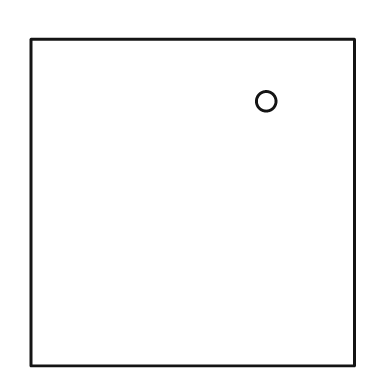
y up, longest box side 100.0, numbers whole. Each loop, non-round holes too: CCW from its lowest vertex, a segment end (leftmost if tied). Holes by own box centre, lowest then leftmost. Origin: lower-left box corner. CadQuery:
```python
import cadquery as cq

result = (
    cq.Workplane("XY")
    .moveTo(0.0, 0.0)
    .lineTo(99.0, 0.0)
    .lineTo(99.0, 100.0)
    .lineTo(0.0, 100.0)
    .close()
    .moveTo(72.0, 81.0)
    .circle(3.0)
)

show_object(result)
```